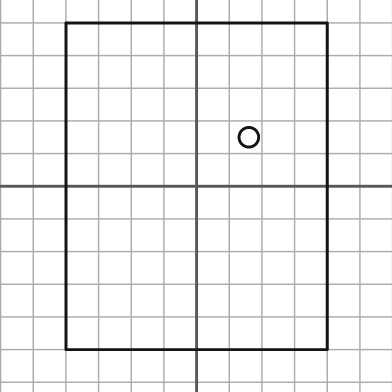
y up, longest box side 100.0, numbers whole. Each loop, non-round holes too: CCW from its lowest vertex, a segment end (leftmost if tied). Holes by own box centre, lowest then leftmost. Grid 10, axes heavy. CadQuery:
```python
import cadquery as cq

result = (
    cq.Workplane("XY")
    .moveTo(-40.0, -50.0)
    .lineTo(40.0, -50.0)
    .lineTo(40.0, 50.0)
    .lineTo(-40.0, 50.0)
    .close()
    .moveTo(16.0, 15.0)
    .circle(3.0)
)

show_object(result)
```